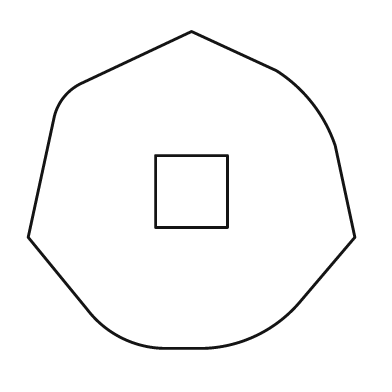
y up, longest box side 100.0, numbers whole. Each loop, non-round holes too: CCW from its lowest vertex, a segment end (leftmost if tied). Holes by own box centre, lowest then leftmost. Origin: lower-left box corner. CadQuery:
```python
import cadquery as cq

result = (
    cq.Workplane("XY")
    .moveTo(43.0, 0.0)
    .lineTo(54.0, 0.0)
    .threePointArc((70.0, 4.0), (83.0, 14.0))
    .lineTo(100.0, 34.0)
    .lineTo(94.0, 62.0)
    .threePointArc((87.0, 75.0), (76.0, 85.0))
    .lineTo(50.0, 97.0)
    .lineTo(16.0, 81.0)
    .threePointArc((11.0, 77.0), (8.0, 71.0))
    .lineTo(0.0, 34.0)
    .lineTo(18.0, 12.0)
    .threePointArc((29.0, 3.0), (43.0, 0.0))
    .close()
    .moveTo(39.0, 37.0)
    .lineTo(61.0, 37.0)
    .lineTo(61.0, 59.0)
    .lineTo(39.0, 59.0)
    .close()
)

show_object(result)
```